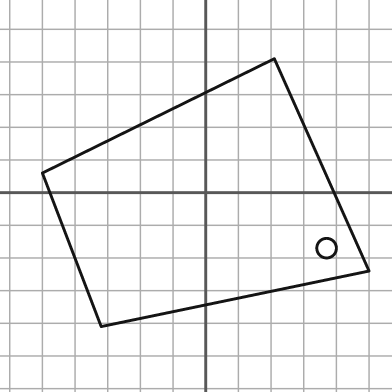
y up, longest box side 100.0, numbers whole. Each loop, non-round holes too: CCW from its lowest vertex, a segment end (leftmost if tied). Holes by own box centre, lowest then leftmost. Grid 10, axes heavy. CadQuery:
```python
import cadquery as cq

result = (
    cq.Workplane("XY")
    .moveTo(-32.0, -41.0)
    .lineTo(50.0, -24.0)
    .lineTo(21.0, 41.0)
    .lineTo(-50.0, 6.0)
    .close()
    .moveTo(37.0, -17.0)
    .circle(3.0)
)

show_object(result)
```